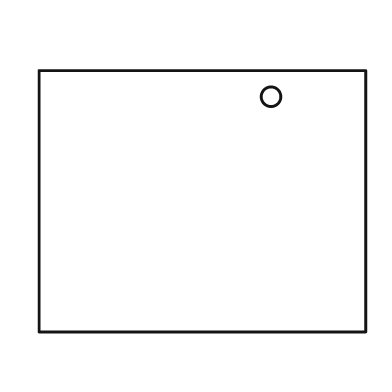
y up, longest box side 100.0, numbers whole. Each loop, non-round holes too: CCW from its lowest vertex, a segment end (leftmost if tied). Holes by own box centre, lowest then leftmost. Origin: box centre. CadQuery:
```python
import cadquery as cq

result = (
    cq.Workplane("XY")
    .moveTo(-50.0, -40.0)
    .lineTo(50.0, -40.0)
    .lineTo(50.0, 40.0)
    .lineTo(-50.0, 40.0)
    .close()
    .moveTo(21.0, 32.0)
    .circle(3.0)
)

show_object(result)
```